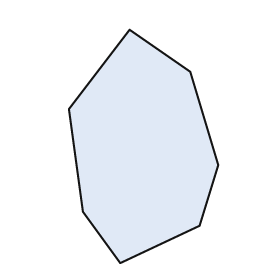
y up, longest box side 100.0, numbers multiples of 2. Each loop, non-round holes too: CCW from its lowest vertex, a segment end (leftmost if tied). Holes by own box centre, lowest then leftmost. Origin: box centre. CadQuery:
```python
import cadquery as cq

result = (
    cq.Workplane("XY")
    .moveTo(-10.0, -50.0)
    .lineTo(24.0, -34.0)
    .lineTo(32.0, -8.0)
    .lineTo(20.0, 32.0)
    .lineTo(-6.0, 50.0)
    .lineTo(-32.0, 16.0)
    .lineTo(-26.0, -28.0)
    .close()
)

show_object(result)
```